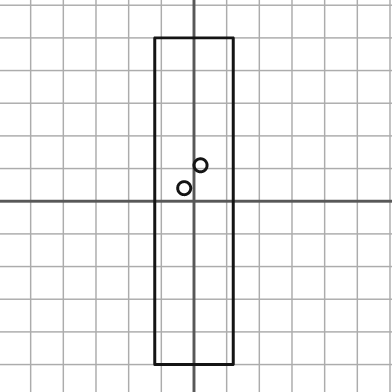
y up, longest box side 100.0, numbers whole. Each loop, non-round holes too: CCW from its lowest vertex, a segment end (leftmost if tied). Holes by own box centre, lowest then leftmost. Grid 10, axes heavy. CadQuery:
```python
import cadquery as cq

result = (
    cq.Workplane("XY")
    .moveTo(-12.0, -50.0)
    .lineTo(12.0, -50.0)
    .lineTo(12.0, 50.0)
    .lineTo(-12.0, 50.0)
    .close()
    .moveTo(-3.0, 4.0)
    .circle(2.0)
    .moveTo(2.0, 11.0)
    .circle(2.0)
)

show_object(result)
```